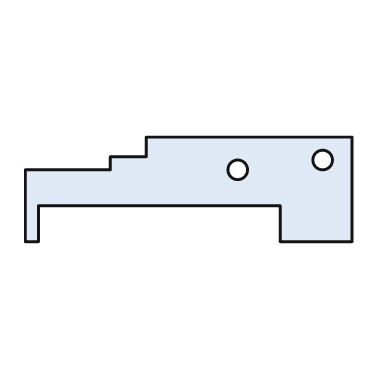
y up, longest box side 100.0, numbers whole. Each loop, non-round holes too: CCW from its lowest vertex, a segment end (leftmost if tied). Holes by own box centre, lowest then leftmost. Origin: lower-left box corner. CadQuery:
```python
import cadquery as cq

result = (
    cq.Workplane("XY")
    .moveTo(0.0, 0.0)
    .lineTo(4.0, 0.0)
    .lineTo(4.0, 11.0)
    .lineTo(78.0, 11.0)
    .lineTo(78.0, 0.0)
    .lineTo(100.0, 0.0)
    .lineTo(100.0, 32.0)
    .lineTo(37.0, 32.0)
    .lineTo(37.0, 26.0)
    .lineTo(26.0, 26.0)
    .lineTo(26.0, 22.0)
    .lineTo(0.0, 22.0)
    .close()
    .moveTo(65.0, 22.0)
    .circle(3.0)
    .moveTo(91.0, 25.0)
    .circle(3.0)
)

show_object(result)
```